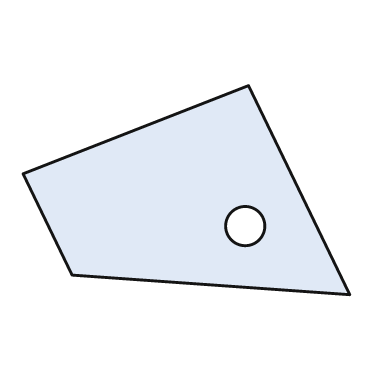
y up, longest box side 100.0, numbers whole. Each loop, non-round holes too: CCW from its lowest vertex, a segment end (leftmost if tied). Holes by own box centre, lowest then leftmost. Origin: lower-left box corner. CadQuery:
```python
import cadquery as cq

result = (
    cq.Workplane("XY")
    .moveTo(100.0, 0.0)
    .lineTo(69.0, 64.0)
    .lineTo(0.0, 37.0)
    .lineTo(15.0, 6.0)
    .close()
    .moveTo(68.0, 21.0)
    .circle(6.0)
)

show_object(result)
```